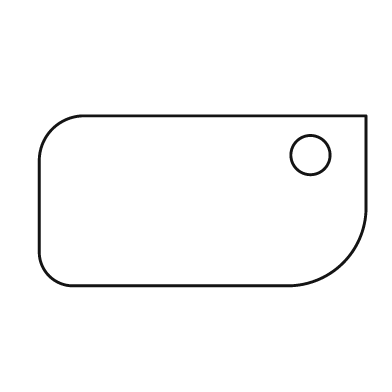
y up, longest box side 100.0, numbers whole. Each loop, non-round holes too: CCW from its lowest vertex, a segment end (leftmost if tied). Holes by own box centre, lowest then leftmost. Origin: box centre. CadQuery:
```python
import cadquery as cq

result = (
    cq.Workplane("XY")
    .moveTo(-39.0, -26.0)
    .lineTo(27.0, -26.0)
    .threePointArc((43.0, -19.0), (50.0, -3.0))
    .lineTo(50.0, 26.0)
    .lineTo(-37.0, 26.0)
    .threePointArc((-46.0, 22.0), (-50.0, 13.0))
    .lineTo(-50.0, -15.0)
    .threePointArc((-47.0, -23.0), (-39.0, -26.0))
    .close()
    .moveTo(33.0, 14.0)
    .circle(6.0)
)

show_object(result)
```